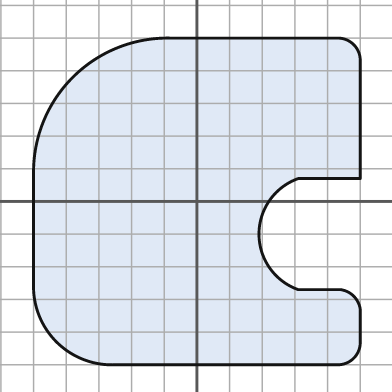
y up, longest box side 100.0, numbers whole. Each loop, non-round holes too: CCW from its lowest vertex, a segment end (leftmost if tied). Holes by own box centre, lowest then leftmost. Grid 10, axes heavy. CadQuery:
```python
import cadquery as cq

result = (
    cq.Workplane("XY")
    .moveTo(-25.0, -50.0)
    .lineTo(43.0, -50.0)
    .threePointArc((48.0, -48.0), (50.0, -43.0))
    .lineTo(50.0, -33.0)
    .threePointArc((48.0, -29.0), (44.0, -27.0))
    .lineTo(31.0, -27.0)
    .threePointArc((19.0, -10.0), (31.0, 7.0))
    .lineTo(50.0, 7.0)
    .lineTo(50.0, 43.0)
    .threePointArc((48.0, 48.0), (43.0, 50.0))
    .lineTo(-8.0, 50.0)
    .threePointArc((-38.0, 38.0), (-50.0, 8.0))
    .lineTo(-50.0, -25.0)
    .threePointArc((-43.0, -43.0), (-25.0, -50.0))
    .close()
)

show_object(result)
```